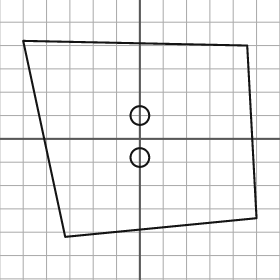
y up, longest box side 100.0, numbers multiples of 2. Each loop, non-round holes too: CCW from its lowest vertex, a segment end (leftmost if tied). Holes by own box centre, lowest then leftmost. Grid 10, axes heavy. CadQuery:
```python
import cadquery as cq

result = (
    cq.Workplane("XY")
    .moveTo(-32.0, -42.0)
    .lineTo(50.0, -34.0)
    .lineTo(46.0, 40.0)
    .lineTo(-50.0, 42.0)
    .close()
    .moveTo(0.0, -8.0)
    .circle(4.0)
    .moveTo(0.0, 10.0)
    .circle(4.0)
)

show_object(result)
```